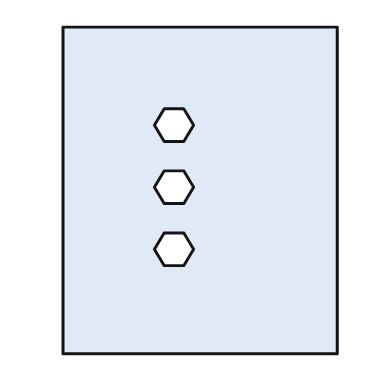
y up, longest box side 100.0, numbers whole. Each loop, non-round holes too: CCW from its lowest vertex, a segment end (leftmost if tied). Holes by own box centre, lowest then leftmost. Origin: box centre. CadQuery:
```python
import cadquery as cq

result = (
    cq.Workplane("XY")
    .moveTo(-42.0, -50.0)
    .lineTo(42.0, -50.0)
    .lineTo(42.0, 50.0)
    .lineTo(-42.0, 50.0)
    .close()
    .moveTo(-11.0, -23.0)
    .lineTo(-5.0, -23.0)
    .lineTo(-2.0, -18.0)
    .lineTo(-5.0, -13.0)
    .lineTo(-11.0, -13.0)
    .lineTo(-14.0, -18.0)
    .close()
    .moveTo(-11.0, -4.0)
    .lineTo(-5.0, -4.0)
    .lineTo(-2.0, 1.0)
    .lineTo(-5.0, 6.0)
    .lineTo(-11.0, 6.0)
    .lineTo(-14.0, 1.0)
    .close()
    .moveTo(-11.0, 15.0)
    .lineTo(-5.0, 15.0)
    .lineTo(-2.0, 20.0)
    .lineTo(-5.0, 25.0)
    .lineTo(-11.0, 25.0)
    .lineTo(-14.0, 20.0)
    .close()
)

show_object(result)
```